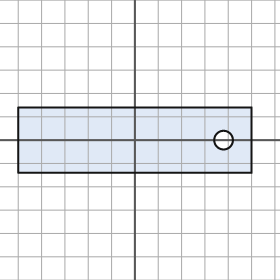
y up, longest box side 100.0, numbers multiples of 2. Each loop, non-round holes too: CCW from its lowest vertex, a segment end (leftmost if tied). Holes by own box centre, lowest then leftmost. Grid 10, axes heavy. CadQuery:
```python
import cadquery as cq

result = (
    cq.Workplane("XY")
    .moveTo(-50.0, -14.0)
    .lineTo(50.0, -14.0)
    .lineTo(50.0, 14.0)
    .lineTo(-50.0, 14.0)
    .close()
    .moveTo(38.0, 0.0)
    .circle(4.0)
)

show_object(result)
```